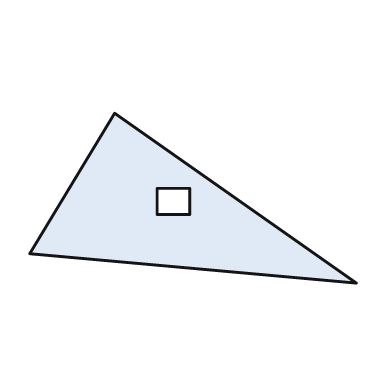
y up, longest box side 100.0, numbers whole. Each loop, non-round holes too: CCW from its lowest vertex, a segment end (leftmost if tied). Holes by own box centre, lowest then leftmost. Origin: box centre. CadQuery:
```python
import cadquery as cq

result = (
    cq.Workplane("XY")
    .moveTo(50.0, -26.0)
    .lineTo(-24.0, 26.0)
    .lineTo(-50.0, -17.0)
    .close()
    .moveTo(-11.0, -5.0)
    .lineTo(-1.0, -5.0)
    .lineTo(-1.0, 3.0)
    .lineTo(-11.0, 3.0)
    .close()
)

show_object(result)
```